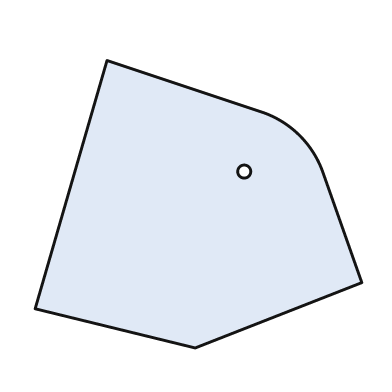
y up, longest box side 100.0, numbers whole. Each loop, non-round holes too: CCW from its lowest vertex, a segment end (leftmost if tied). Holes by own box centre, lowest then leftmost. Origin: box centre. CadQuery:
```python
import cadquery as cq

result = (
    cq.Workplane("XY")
    .moveTo(-1.0, -44.0)
    .lineTo(50.0, -24.0)
    .lineTo(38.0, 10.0)
    .threePointArc((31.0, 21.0), (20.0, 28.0))
    .lineTo(-28.0, 44.0)
    .lineTo(-50.0, -32.0)
    .close()
    .moveTo(14.0, 10.0)
    .circle(2.0)
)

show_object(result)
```